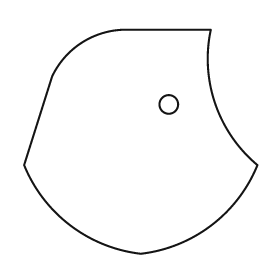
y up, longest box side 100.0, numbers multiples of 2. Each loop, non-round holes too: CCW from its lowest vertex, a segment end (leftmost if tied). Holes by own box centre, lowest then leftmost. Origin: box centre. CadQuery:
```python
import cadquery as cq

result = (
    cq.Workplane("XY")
    .moveTo(0.0, -48.0)
    .threePointArc((30.0, -36.0), (50.0, -10.0))
    .threePointArc((32.0, 16.0), (30.0, 48.0))
    .lineTo(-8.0, 48.0)
    .threePointArc((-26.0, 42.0), (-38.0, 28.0))
    .lineTo(-50.0, -10.0)
    .threePointArc((-30.0, -36.0), (0.0, -48.0))
    .close()
    .moveTo(12.0, 16.0)
    .circle(4.0)
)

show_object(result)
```